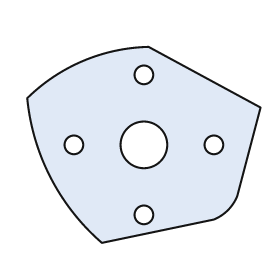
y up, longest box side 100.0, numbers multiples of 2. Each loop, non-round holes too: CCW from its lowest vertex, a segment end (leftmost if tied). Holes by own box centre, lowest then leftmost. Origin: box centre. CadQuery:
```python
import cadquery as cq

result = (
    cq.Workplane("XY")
    .moveTo(-18.0, -42.0)
    .lineTo(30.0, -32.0)
    .threePointArc((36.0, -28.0), (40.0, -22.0))
    .lineTo(50.0, 16.0)
    .lineTo(2.0, 42.0)
    .threePointArc((-26.0, 36.0), (-50.0, 20.0))
    .threePointArc((-40.0, -14.0), (-18.0, -42.0))
    .close()
    .moveTo(0.0, -30.0)
    .circle(4.0)
    .moveTo(-30.0, 0.0)
    .circle(4.0)
    .moveTo(0.0, 0.0)
    .circle(10.0)
    .moveTo(30.0, 0.0)
    .circle(4.0)
    .moveTo(0.0, 30.0)
    .circle(4.0)
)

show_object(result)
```